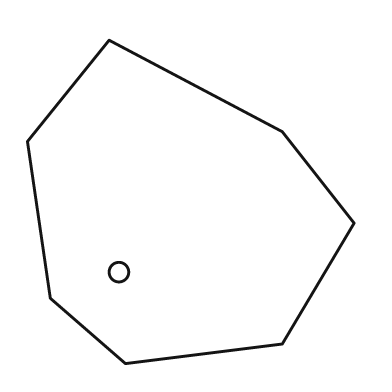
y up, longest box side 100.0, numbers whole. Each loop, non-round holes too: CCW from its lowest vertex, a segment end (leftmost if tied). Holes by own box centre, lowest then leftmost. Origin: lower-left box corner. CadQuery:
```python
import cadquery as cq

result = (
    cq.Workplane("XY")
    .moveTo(30.0, 0.0)
    .lineTo(78.0, 6.0)
    .lineTo(100.0, 43.0)
    .lineTo(78.0, 71.0)
    .lineTo(25.0, 99.0)
    .lineTo(0.0, 68.0)
    .lineTo(7.0, 20.0)
    .close()
    .moveTo(28.0, 28.0)
    .circle(3.0)
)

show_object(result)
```